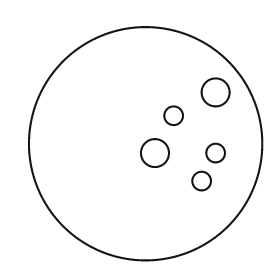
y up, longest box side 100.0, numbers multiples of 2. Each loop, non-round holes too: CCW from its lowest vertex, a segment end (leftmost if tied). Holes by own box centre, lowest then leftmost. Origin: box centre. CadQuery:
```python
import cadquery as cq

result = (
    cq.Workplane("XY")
    .moveTo(0.0, 0.0)
    .circle(50.0)
    .moveTo(24.0, -16.0)
    .circle(4.0)
    .moveTo(4.0, -4.0)
    .circle(6.0)
    .moveTo(30.0, -4.0)
    .circle(4.0)
    .moveTo(12.0, 12.0)
    .circle(4.0)
    .moveTo(30.0, 22.0)
    .circle(6.0)
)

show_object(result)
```